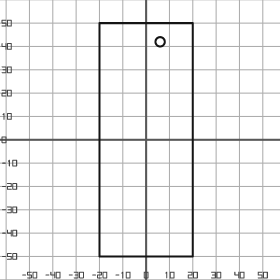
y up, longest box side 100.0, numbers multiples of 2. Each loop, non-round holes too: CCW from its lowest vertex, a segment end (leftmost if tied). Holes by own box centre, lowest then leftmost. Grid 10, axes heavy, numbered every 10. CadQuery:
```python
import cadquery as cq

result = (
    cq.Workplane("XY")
    .moveTo(-20.0, -50.0)
    .lineTo(20.0, -50.0)
    .lineTo(20.0, 50.0)
    .lineTo(-20.0, 50.0)
    .close()
    .moveTo(6.0, 42.0)
    .circle(2.0)
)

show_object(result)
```